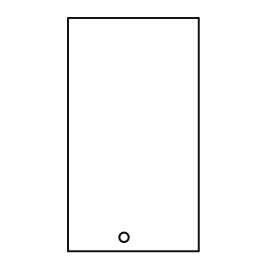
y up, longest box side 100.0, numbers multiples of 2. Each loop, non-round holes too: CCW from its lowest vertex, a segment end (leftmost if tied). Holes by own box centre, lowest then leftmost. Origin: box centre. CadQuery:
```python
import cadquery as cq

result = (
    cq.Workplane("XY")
    .moveTo(-28.0, -50.0)
    .lineTo(28.0, -50.0)
    .lineTo(28.0, 50.0)
    .lineTo(-28.0, 50.0)
    .close()
    .moveTo(-4.0, -44.0)
    .circle(2.0)
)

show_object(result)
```